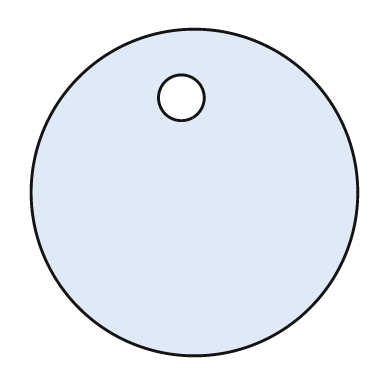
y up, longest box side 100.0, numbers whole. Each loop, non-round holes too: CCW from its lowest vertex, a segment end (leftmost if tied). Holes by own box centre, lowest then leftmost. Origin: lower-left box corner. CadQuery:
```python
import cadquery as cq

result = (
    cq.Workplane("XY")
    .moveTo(50.0, 50.0)
    .circle(50.0)
    .moveTo(46.0, 79.0)
    .circle(7.0)
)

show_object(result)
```